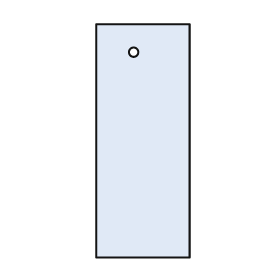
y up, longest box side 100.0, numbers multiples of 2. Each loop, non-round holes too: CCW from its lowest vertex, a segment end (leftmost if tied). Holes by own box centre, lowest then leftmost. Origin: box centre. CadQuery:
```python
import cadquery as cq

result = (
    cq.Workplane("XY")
    .moveTo(-20.0, -50.0)
    .lineTo(20.0, -50.0)
    .lineTo(20.0, 50.0)
    .lineTo(-20.0, 50.0)
    .close()
    .moveTo(-4.0, 38.0)
    .circle(2.0)
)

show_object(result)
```